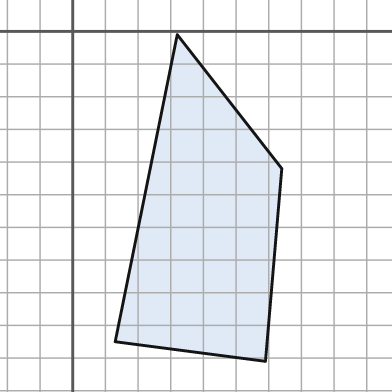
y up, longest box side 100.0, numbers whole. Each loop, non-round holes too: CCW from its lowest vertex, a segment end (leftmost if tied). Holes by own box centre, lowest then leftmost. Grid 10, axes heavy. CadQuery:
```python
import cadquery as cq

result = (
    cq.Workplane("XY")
    .moveTo(59.0, -101.0)
    .lineTo(64.0, -42.0)
    .lineTo(32.0, -1.0)
    .lineTo(13.0, -95.0)
    .close()
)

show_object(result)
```